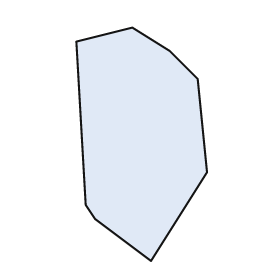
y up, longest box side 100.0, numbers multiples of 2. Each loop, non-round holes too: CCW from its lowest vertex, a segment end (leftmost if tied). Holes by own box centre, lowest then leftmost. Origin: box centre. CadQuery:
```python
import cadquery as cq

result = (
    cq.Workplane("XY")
    .moveTo(4.0, -50.0)
    .lineTo(28.0, -12.0)
    .lineTo(24.0, 28.0)
    .lineTo(12.0, 40.0)
    .lineTo(-4.0, 50.0)
    .lineTo(-28.0, 44.0)
    .lineTo(-24.0, -26.0)
    .lineTo(-20.0, -32.0)
    .close()
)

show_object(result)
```